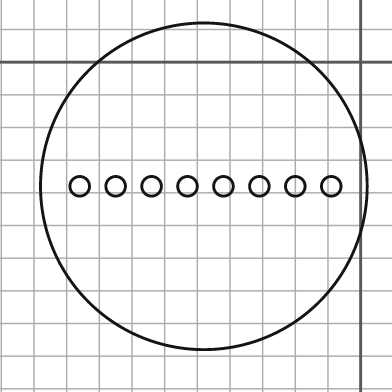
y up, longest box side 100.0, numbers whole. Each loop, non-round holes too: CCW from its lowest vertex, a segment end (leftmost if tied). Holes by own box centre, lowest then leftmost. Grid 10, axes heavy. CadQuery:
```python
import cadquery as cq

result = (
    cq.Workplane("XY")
    .moveTo(-48.0, -38.0)
    .circle(50.0)
    .moveTo(-86.0, -38.0)
    .circle(3.0)
    .moveTo(-75.0, -38.0)
    .circle(3.0)
    .moveTo(-64.0, -38.0)
    .circle(3.0)
    .moveTo(-53.0, -38.0)
    .circle(3.0)
    .moveTo(-42.0, -38.0)
    .circle(3.0)
    .moveTo(-31.0, -38.0)
    .circle(3.0)
    .moveTo(-20.0, -38.0)
    .circle(3.0)
    .moveTo(-9.0, -38.0)
    .circle(3.0)
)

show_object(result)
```